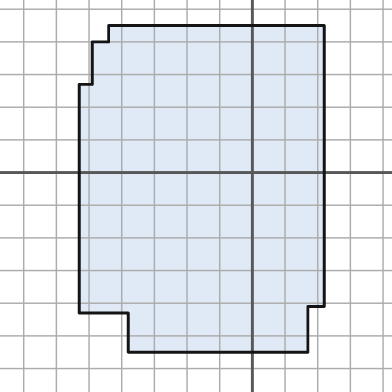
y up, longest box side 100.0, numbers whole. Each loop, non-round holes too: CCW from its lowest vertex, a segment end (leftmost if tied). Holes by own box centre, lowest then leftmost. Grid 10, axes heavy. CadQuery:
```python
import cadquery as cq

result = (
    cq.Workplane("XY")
    .moveTo(-38.0, -55.0)
    .lineTo(17.0, -55.0)
    .lineTo(17.0, -41.0)
    .lineTo(22.0, -41.0)
    .lineTo(22.0, 45.0)
    .lineTo(-44.0, 45.0)
    .lineTo(-44.0, 40.0)
    .lineTo(-49.0, 40.0)
    .lineTo(-49.0, 27.0)
    .lineTo(-53.0, 27.0)
    .lineTo(-53.0, -43.0)
    .lineTo(-38.0, -43.0)
    .close()
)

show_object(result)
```